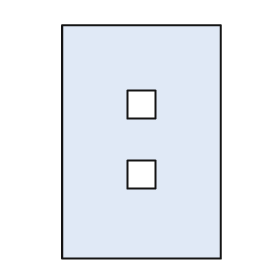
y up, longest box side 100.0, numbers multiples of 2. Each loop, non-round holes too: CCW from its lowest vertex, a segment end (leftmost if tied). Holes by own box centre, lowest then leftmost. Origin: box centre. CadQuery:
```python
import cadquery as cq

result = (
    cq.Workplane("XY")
    .moveTo(-34.0, -50.0)
    .lineTo(34.0, -50.0)
    .lineTo(34.0, 50.0)
    .lineTo(-34.0, 50.0)
    .close()
    .moveTo(-6.0, -20.0)
    .lineTo(6.0, -20.0)
    .lineTo(6.0, -8.0)
    .lineTo(-6.0, -8.0)
    .close()
    .moveTo(-6.0, 10.0)
    .lineTo(6.0, 10.0)
    .lineTo(6.0, 22.0)
    .lineTo(-6.0, 22.0)
    .close()
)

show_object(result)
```